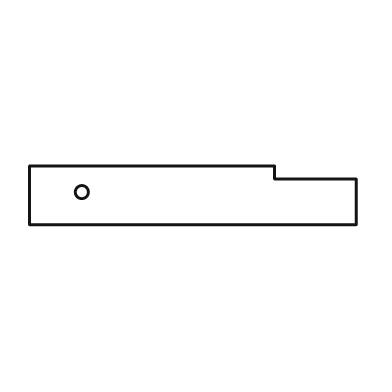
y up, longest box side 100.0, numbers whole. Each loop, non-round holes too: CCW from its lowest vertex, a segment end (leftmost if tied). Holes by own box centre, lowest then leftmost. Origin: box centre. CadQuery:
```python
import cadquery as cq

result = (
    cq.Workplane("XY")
    .moveTo(-50.0, -9.0)
    .lineTo(50.0, -9.0)
    .lineTo(50.0, 5.0)
    .lineTo(25.0, 5.0)
    .lineTo(25.0, 9.0)
    .lineTo(-50.0, 9.0)
    .close()
    .moveTo(-34.0, 1.0)
    .circle(2.0)
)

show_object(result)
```